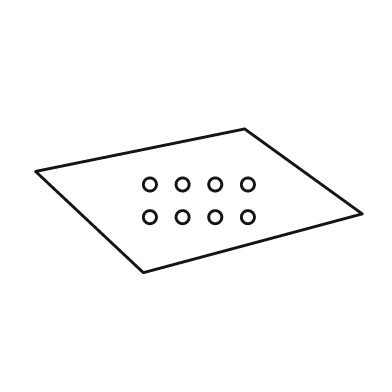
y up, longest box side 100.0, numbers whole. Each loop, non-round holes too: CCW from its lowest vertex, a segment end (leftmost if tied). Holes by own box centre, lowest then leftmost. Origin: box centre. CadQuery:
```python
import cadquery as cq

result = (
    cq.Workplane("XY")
    .moveTo(-17.0, -22.0)
    .lineTo(50.0, -4.0)
    .lineTo(14.0, 22.0)
    .lineTo(-50.0, 9.0)
    .close()
    .moveTo(-15.0, -5.0)
    .circle(2.0)
    .moveTo(-5.0, -5.0)
    .circle(2.0)
    .moveTo(5.0, -5.0)
    .circle(2.0)
    .moveTo(15.0, -5.0)
    .circle(2.0)
    .moveTo(-15.0, 5.0)
    .circle(2.0)
    .moveTo(-5.0, 5.0)
    .circle(2.0)
    .moveTo(5.0, 5.0)
    .circle(2.0)
    .moveTo(15.0, 5.0)
    .circle(2.0)
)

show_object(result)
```